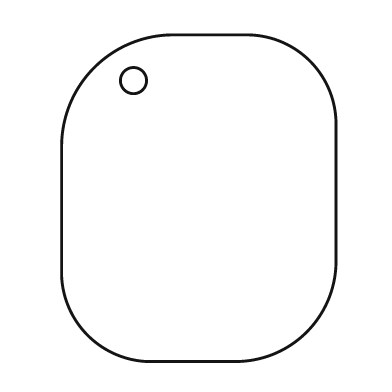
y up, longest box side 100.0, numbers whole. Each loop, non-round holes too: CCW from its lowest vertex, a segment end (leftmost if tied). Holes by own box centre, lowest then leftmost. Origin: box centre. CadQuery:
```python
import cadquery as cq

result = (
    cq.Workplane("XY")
    .moveTo(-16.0, -50.0)
    .lineTo(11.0, -50.0)
    .threePointArc((33.0, -41.0), (42.0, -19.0))
    .lineTo(42.0, 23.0)
    .threePointArc((34.0, 42.0), (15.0, 50.0))
    .lineTo(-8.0, 50.0)
    .threePointArc((-32.0, 40.0), (-42.0, 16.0))
    .lineTo(-42.0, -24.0)
    .threePointArc((-34.0, -42.0), (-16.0, -50.0))
    .close()
    .moveTo(-20.0, 36.0)
    .circle(4.0)
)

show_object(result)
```